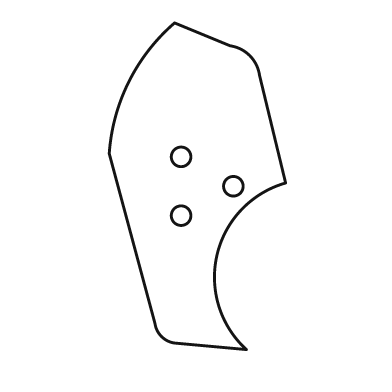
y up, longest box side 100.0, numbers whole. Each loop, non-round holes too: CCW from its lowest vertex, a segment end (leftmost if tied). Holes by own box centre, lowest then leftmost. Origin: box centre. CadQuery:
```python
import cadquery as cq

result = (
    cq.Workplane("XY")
    .moveTo(15.0, -50.0)
    .threePointArc((6.0, -21.0), (27.0, 1.0))
    .lineTo(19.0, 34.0)
    .threePointArc((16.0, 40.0), (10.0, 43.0))
    .lineTo(-7.0, 50.0)
    .threePointArc((-21.0, 32.0), (-27.0, 10.0))
    .lineTo(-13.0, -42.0)
    .threePointArc((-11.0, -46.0), (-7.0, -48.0))
    .close()
    .moveTo(-5.0, -9.0)
    .circle(3.0)
    .moveTo(11.0, 0.0)
    .circle(3.0)
    .moveTo(-5.0, 9.0)
    .circle(3.0)
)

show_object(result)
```